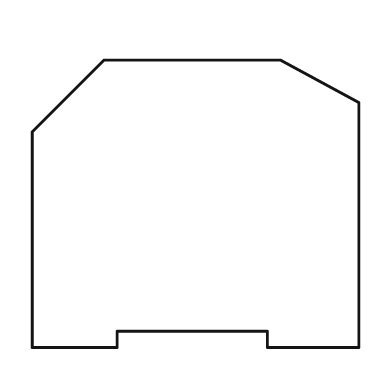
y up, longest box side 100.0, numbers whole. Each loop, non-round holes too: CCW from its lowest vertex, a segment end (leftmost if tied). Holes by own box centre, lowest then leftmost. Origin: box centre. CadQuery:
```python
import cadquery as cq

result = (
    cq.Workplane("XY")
    .moveTo(-50.0, -44.0)
    .lineTo(-24.0, -44.0)
    .lineTo(-24.0, -39.0)
    .lineTo(22.0, -39.0)
    .lineTo(22.0, -44.0)
    .lineTo(50.0, -44.0)
    .lineTo(50.0, 31.0)
    .lineTo(26.0, 44.0)
    .lineTo(-28.0, 44.0)
    .lineTo(-50.0, 22.0)
    .close()
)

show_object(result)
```